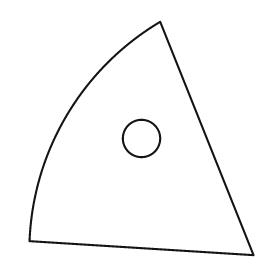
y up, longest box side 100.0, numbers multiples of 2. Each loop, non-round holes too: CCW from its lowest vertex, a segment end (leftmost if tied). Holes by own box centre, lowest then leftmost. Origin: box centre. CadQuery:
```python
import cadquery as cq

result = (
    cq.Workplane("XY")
    .moveTo(48.0, -50.0)
    .lineTo(8.0, 50.0)
    .threePointArc((-32.0, 10.0), (-48.0, -44.0))
    .close()
    .moveTo(0.0, 0.0)
    .circle(8.0)
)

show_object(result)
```